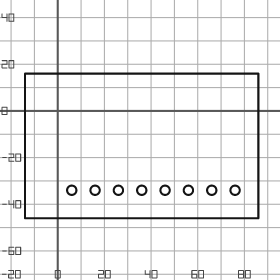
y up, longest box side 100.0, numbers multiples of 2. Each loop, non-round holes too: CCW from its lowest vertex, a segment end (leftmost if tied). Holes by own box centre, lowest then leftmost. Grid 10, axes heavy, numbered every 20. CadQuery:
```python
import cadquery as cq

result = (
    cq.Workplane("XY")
    .moveTo(-14.0, -46.0)
    .lineTo(86.0, -46.0)
    .lineTo(86.0, 16.0)
    .lineTo(-14.0, 16.0)
    .close()
    .moveTo(6.0, -34.0)
    .circle(2.0)
    .moveTo(16.0, -34.0)
    .circle(2.0)
    .moveTo(26.0, -34.0)
    .circle(2.0)
    .moveTo(36.0, -34.0)
    .circle(2.0)
    .moveTo(46.0, -34.0)
    .circle(2.0)
    .moveTo(56.0, -34.0)
    .circle(2.0)
    .moveTo(66.0, -34.0)
    .circle(2.0)
    .moveTo(76.0, -34.0)
    .circle(2.0)
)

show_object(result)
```